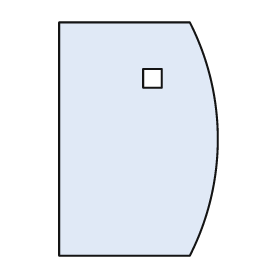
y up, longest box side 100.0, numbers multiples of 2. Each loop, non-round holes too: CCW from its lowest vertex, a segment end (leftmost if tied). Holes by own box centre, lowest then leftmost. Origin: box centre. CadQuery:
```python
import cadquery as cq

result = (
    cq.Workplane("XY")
    .moveTo(-34.0, -50.0)
    .lineTo(22.0, -50.0)
    .threePointArc((34.0, 0.0), (22.0, 50.0))
    .lineTo(-34.0, 50.0)
    .close()
    .moveTo(2.0, 22.0)
    .lineTo(10.0, 22.0)
    .lineTo(10.0, 30.0)
    .lineTo(2.0, 30.0)
    .close()
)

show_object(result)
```